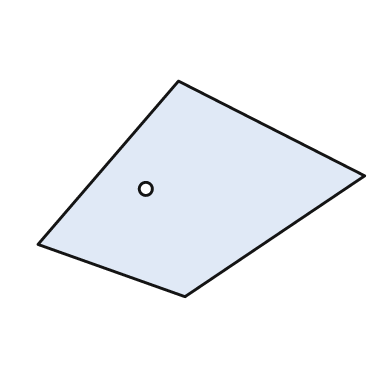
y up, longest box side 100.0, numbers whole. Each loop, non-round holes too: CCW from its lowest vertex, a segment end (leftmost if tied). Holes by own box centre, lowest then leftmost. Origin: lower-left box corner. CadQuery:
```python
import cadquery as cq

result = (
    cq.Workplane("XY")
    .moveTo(45.0, 0.0)
    .lineTo(100.0, 37.0)
    .lineTo(43.0, 66.0)
    .lineTo(0.0, 16.0)
    .close()
    .moveTo(33.0, 33.0)
    .circle(2.0)
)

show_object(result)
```